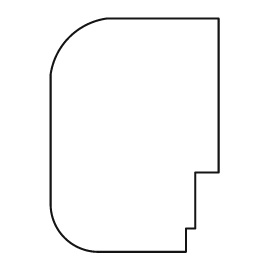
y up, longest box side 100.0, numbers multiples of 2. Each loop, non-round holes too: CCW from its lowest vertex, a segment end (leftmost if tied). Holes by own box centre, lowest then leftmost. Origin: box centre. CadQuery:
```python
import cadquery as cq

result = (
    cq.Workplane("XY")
    .moveTo(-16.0, -50.0)
    .lineTo(22.0, -50.0)
    .lineTo(22.0, -40.0)
    .lineTo(26.0, -40.0)
    .lineTo(26.0, -16.0)
    .lineTo(36.0, -16.0)
    .lineTo(36.0, 50.0)
    .lineTo(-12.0, 50.0)
    .threePointArc((-28.0, 42.0), (-36.0, 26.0))
    .lineTo(-36.0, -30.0)
    .threePointArc((-30.0, -44.0), (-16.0, -50.0))
    .close()
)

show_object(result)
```